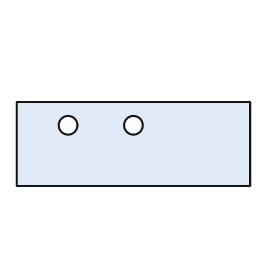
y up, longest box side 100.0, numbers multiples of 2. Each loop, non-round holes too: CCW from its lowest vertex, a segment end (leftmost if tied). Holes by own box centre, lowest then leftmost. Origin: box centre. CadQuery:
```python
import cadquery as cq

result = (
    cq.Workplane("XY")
    .moveTo(-50.0, -18.0)
    .lineTo(50.0, -18.0)
    .lineTo(50.0, 18.0)
    .lineTo(-50.0, 18.0)
    .close()
    .moveTo(-28.0, 8.0)
    .circle(4.0)
    .moveTo(0.0, 8.0)
    .circle(4.0)
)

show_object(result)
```